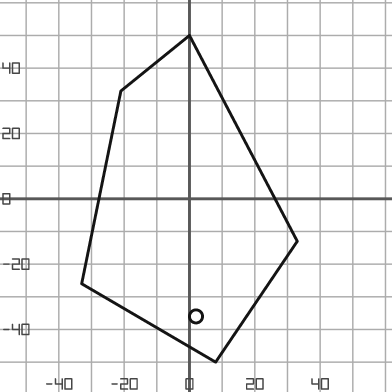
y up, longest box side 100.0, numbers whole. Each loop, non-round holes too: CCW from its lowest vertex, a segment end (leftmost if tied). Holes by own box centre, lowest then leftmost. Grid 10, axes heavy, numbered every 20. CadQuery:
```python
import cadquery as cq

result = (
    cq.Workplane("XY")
    .moveTo(8.0, -50.0)
    .lineTo(33.0, -13.0)
    .lineTo(0.0, 50.0)
    .lineTo(-21.0, 33.0)
    .lineTo(-33.0, -26.0)
    .close()
    .moveTo(2.0, -36.0)
    .circle(2.0)
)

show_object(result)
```